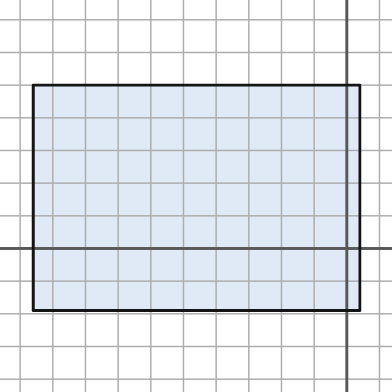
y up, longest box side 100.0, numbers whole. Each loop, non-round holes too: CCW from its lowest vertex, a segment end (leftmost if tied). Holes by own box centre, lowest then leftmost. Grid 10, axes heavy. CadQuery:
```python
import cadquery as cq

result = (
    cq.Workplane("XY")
    .moveTo(-96.0, -19.0)
    .lineTo(4.0, -19.0)
    .lineTo(4.0, 50.0)
    .lineTo(-96.0, 50.0)
    .close()
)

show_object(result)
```